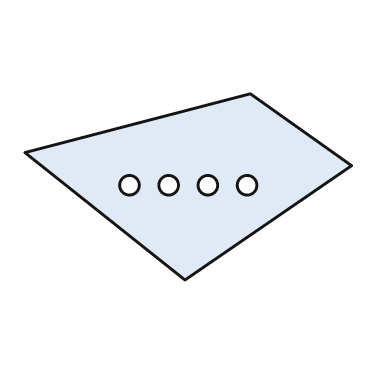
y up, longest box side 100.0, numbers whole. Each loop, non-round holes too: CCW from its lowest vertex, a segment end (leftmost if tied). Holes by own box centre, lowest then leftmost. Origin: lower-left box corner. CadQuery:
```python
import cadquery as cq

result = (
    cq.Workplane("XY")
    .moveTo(49.0, 0.0)
    .lineTo(100.0, 35.0)
    .lineTo(69.0, 57.0)
    .lineTo(0.0, 39.0)
    .close()
    .moveTo(32.0, 29.0)
    .circle(3.0)
    .moveTo(44.0, 29.0)
    .circle(3.0)
    .moveTo(56.0, 29.0)
    .circle(3.0)
    .moveTo(68.0, 29.0)
    .circle(3.0)
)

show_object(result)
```